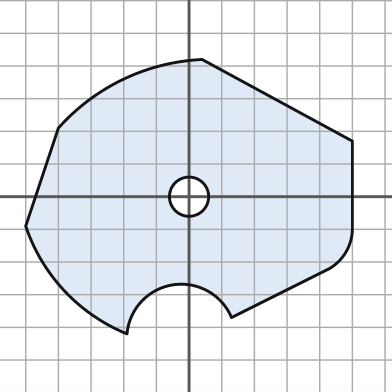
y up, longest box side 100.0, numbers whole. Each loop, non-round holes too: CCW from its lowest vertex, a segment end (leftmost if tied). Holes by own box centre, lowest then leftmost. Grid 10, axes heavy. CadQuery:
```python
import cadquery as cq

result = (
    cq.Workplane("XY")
    .moveTo(-19.0, -42.0)
    .threePointArc((-5.0, -27.0), (13.0, -37.0))
    .lineTo(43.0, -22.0)
    .threePointArc((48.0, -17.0), (50.0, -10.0))
    .lineTo(50.0, 17.0)
    .lineTo(4.0, 42.0)
    .threePointArc((-20.0, 36.0), (-40.0, 21.0))
    .lineTo(-50.0, -9.0)
    .threePointArc((-38.0, -29.0), (-19.0, -42.0))
    .close()
    .moveTo(0.0, 0.0)
    .circle(6.0)
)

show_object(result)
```